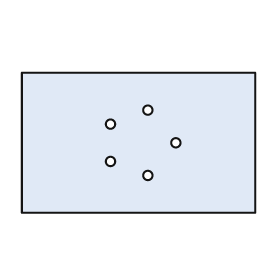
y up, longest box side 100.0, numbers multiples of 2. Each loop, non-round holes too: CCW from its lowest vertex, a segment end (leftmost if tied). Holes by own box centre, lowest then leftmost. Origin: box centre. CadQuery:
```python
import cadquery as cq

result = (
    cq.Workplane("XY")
    .moveTo(-50.0, -30.0)
    .lineTo(50.0, -30.0)
    .lineTo(50.0, 30.0)
    .lineTo(-50.0, 30.0)
    .close()
    .moveTo(4.0, -14.0)
    .circle(2.0)
    .moveTo(-12.0, -8.0)
    .circle(2.0)
    .moveTo(16.0, 0.0)
    .circle(2.0)
    .moveTo(-12.0, 8.0)
    .circle(2.0)
    .moveTo(4.0, 14.0)
    .circle(2.0)
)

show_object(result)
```